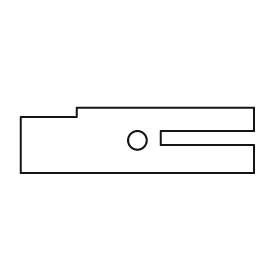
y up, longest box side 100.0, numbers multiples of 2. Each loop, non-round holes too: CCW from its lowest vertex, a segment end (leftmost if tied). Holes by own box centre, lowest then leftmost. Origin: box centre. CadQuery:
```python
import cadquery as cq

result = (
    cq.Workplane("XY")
    .moveTo(-50.0, -14.0)
    .lineTo(50.0, -14.0)
    .lineTo(50.0, -2.0)
    .lineTo(10.0, -2.0)
    .lineTo(10.0, 4.0)
    .lineTo(50.0, 4.0)
    .lineTo(50.0, 14.0)
    .lineTo(-26.0, 14.0)
    .lineTo(-26.0, 10.0)
    .lineTo(-50.0, 10.0)
    .close()
    .moveTo(0.0, 0.0)
    .circle(4.0)
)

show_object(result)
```